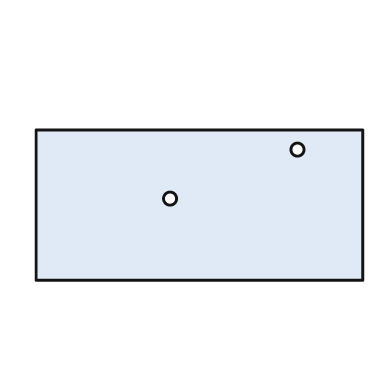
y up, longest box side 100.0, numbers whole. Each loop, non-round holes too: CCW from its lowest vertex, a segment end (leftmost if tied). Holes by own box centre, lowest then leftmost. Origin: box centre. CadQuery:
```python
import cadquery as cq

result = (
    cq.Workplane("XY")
    .moveTo(-50.0, -23.0)
    .lineTo(50.0, -23.0)
    .lineTo(50.0, 23.0)
    .lineTo(-50.0, 23.0)
    .close()
    .moveTo(-9.0, 2.0)
    .circle(2.0)
    .moveTo(30.0, 17.0)
    .circle(2.0)
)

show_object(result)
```